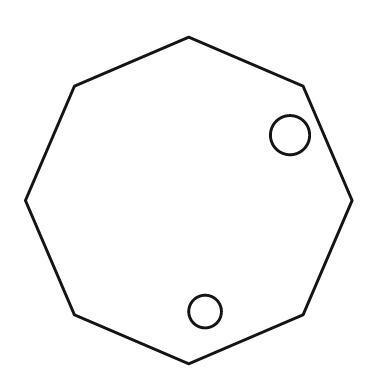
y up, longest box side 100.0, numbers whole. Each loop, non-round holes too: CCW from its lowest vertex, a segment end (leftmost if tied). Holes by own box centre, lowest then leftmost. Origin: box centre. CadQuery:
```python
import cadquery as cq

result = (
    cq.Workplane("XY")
    .moveTo(0.0, -50.0)
    .lineTo(35.0, -35.0)
    .lineTo(50.0, 0.0)
    .lineTo(35.0, 35.0)
    .lineTo(0.0, 50.0)
    .lineTo(-35.0, 35.0)
    .lineTo(-50.0, 0.0)
    .lineTo(-35.0, -35.0)
    .close()
    .moveTo(5.0, -34.0)
    .circle(5.0)
    .moveTo(31.0, 20.0)
    .circle(6.0)
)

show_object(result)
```